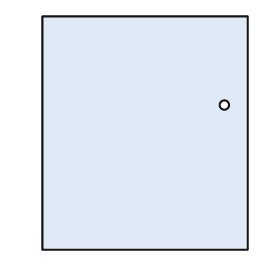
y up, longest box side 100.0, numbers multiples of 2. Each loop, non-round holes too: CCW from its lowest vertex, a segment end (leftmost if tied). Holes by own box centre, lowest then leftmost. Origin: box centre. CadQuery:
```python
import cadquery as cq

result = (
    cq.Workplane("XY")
    .moveTo(-44.0, -50.0)
    .lineTo(44.0, -50.0)
    .lineTo(44.0, 50.0)
    .lineTo(-44.0, 50.0)
    .close()
    .moveTo(34.0, 12.0)
    .circle(2.0)
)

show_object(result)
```